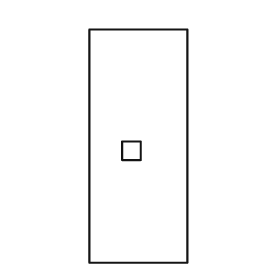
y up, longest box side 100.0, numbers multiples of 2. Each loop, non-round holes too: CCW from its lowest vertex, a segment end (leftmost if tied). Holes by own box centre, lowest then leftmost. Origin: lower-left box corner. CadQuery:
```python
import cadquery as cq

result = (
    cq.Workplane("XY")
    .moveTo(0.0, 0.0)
    .lineTo(42.0, 0.0)
    .lineTo(42.0, 100.0)
    .lineTo(0.0, 100.0)
    .close()
    .moveTo(14.0, 44.0)
    .lineTo(22.0, 44.0)
    .lineTo(22.0, 52.0)
    .lineTo(14.0, 52.0)
    .close()
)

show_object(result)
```